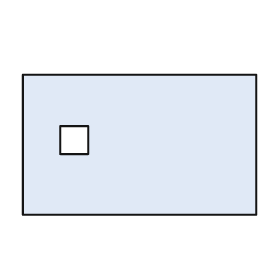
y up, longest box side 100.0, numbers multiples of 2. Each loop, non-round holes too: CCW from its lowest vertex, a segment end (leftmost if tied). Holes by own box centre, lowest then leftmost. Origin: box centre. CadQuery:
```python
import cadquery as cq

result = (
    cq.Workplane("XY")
    .moveTo(-50.0, -30.0)
    .lineTo(50.0, -30.0)
    .lineTo(50.0, 30.0)
    .lineTo(-50.0, 30.0)
    .close()
    .moveTo(-34.0, -4.0)
    .lineTo(-22.0, -4.0)
    .lineTo(-22.0, 8.0)
    .lineTo(-34.0, 8.0)
    .close()
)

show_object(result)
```